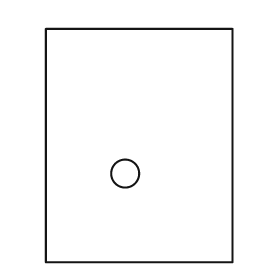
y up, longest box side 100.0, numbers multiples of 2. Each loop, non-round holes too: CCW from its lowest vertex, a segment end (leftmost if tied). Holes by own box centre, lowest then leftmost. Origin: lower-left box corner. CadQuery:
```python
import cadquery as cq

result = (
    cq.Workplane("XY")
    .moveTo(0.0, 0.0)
    .lineTo(80.0, 0.0)
    .lineTo(80.0, 100.0)
    .lineTo(0.0, 100.0)
    .close()
    .moveTo(34.0, 38.0)
    .circle(6.0)
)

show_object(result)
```